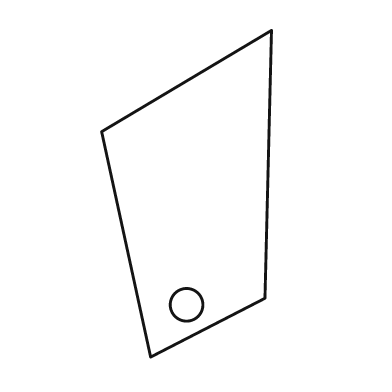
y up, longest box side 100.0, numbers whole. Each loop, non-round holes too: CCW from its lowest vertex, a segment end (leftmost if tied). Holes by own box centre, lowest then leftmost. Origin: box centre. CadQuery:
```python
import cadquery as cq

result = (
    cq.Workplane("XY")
    .moveTo(-11.0, -50.0)
    .lineTo(24.0, -32.0)
    .lineTo(26.0, 50.0)
    .lineTo(-26.0, 19.0)
    .close()
    .moveTo(0.0, -34.0)
    .circle(5.0)
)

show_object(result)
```